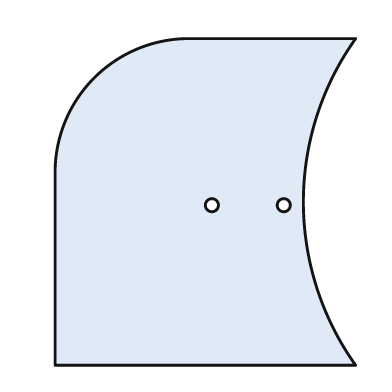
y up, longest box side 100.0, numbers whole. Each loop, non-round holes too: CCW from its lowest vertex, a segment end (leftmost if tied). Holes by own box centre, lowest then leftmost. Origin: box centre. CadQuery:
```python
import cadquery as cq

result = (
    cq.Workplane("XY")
    .moveTo(-46.0, -50.0)
    .lineTo(46.0, -50.0)
    .threePointArc((30.0, 0.0), (46.0, 50.0))
    .lineTo(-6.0, 50.0)
    .threePointArc((-34.0, 38.0), (-46.0, 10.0))
    .close()
    .moveTo(2.0, -1.0)
    .circle(2.0)
    .moveTo(24.0, -1.0)
    .circle(2.0)
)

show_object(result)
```